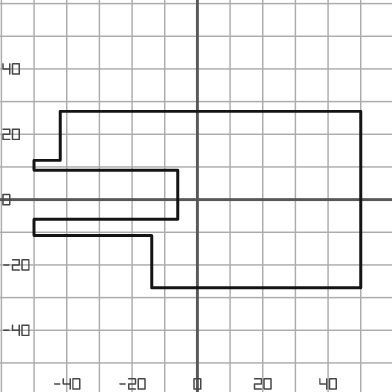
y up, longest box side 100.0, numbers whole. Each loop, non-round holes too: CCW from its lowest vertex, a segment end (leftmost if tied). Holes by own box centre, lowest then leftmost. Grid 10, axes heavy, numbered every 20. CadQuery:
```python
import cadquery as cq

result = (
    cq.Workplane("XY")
    .moveTo(-14.0, -27.0)
    .lineTo(50.0, -27.0)
    .lineTo(50.0, 27.0)
    .lineTo(-42.0, 27.0)
    .lineTo(-42.0, 12.0)
    .lineTo(-50.0, 12.0)
    .lineTo(-50.0, 9.0)
    .lineTo(-6.0, 9.0)
    .lineTo(-6.0, -6.0)
    .lineTo(-50.0, -6.0)
    .lineTo(-50.0, -11.0)
    .lineTo(-14.0, -11.0)
    .close()
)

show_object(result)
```